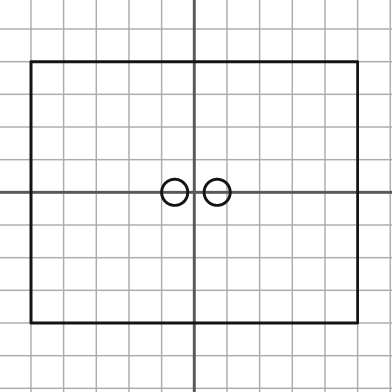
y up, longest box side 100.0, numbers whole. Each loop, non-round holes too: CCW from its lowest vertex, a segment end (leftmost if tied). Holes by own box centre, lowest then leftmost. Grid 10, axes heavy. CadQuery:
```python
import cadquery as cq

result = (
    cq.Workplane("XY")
    .moveTo(-50.0, -40.0)
    .lineTo(50.0, -40.0)
    .lineTo(50.0, 40.0)
    .lineTo(-50.0, 40.0)
    .close()
    .moveTo(-6.0, 0.0)
    .circle(4.0)
    .moveTo(7.0, 0.0)
    .circle(4.0)
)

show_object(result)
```